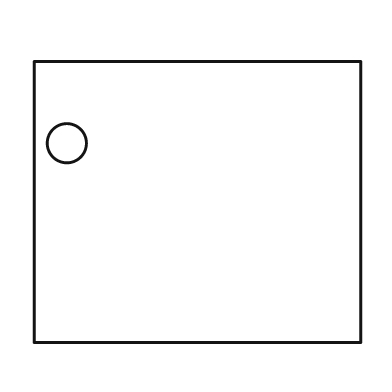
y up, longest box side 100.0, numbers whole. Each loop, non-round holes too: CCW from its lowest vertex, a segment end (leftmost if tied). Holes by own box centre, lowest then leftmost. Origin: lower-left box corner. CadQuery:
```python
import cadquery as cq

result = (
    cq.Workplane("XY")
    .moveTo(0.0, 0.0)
    .lineTo(100.0, 0.0)
    .lineTo(100.0, 86.0)
    .lineTo(0.0, 86.0)
    .close()
    .moveTo(10.0, 61.0)
    .circle(6.0)
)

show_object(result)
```